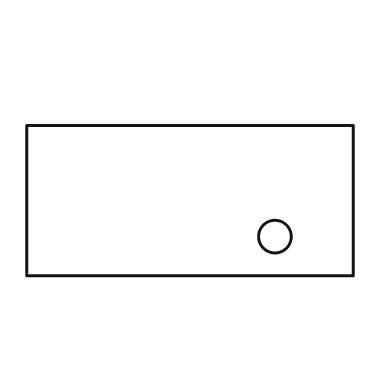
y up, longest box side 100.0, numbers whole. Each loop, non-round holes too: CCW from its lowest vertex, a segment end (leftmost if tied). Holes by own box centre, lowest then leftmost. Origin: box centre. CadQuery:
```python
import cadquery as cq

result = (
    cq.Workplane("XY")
    .moveTo(-50.0, -23.0)
    .lineTo(50.0, -23.0)
    .lineTo(50.0, 23.0)
    .lineTo(-50.0, 23.0)
    .close()
    .moveTo(26.0, -11.0)
    .circle(5.0)
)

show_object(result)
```